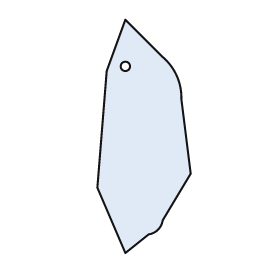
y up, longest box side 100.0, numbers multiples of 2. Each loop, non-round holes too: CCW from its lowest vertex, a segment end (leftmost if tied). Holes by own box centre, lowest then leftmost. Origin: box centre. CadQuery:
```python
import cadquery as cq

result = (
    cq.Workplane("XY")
    .moveTo(-8.0, -50.0)
    .lineTo(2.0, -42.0)
    .threePointArc((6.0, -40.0), (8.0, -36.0))
    .lineTo(20.0, -16.0)
    .lineTo(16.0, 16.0)
    .threePointArc((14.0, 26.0), (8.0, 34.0))
    .lineTo(-8.0, 50.0)
    .lineTo(-16.0, 28.0)
    .lineTo(-20.0, -22.0)
    .close()
    .moveTo(-8.0, 30.0)
    .circle(2.0)
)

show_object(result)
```